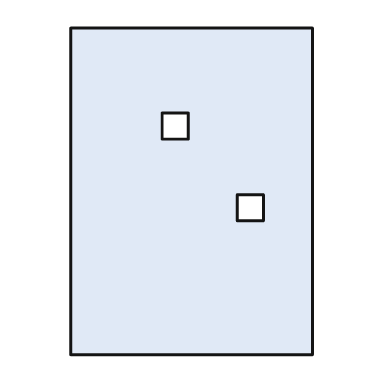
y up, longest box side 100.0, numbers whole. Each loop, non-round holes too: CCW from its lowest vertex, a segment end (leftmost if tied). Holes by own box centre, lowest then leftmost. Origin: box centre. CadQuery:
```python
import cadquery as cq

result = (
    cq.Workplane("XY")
    .moveTo(-37.0, -50.0)
    .lineTo(37.0, -50.0)
    .lineTo(37.0, 50.0)
    .lineTo(-37.0, 50.0)
    .close()
    .moveTo(14.0, -9.0)
    .lineTo(22.0, -9.0)
    .lineTo(22.0, -1.0)
    .lineTo(14.0, -1.0)
    .close()
    .moveTo(-9.0, 16.0)
    .lineTo(-1.0, 16.0)
    .lineTo(-1.0, 24.0)
    .lineTo(-9.0, 24.0)
    .close()
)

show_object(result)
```